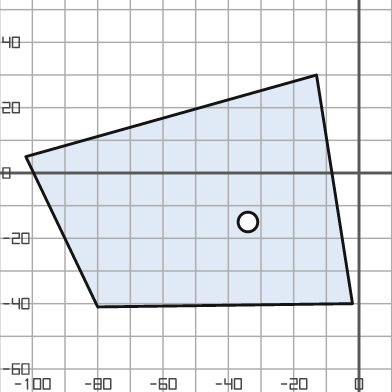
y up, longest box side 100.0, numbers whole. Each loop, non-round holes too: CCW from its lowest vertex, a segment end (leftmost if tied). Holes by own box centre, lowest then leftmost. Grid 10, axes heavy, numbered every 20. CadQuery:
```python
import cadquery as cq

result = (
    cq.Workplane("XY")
    .moveTo(-80.0, -41.0)
    .lineTo(-2.0, -40.0)
    .lineTo(-13.0, 30.0)
    .lineTo(-102.0, 5.0)
    .close()
    .moveTo(-34.0, -15.0)
    .circle(3.0)
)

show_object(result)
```